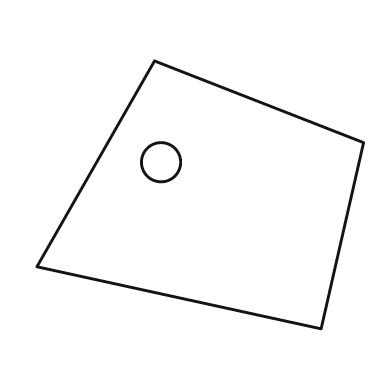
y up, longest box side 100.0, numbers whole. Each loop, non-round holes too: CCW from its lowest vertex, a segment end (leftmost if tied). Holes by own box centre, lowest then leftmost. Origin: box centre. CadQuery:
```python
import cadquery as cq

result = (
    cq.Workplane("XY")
    .moveTo(37.0, -41.0)
    .lineTo(50.0, 16.0)
    .lineTo(-14.0, 41.0)
    .lineTo(-50.0, -22.0)
    .close()
    .moveTo(-12.0, 10.0)
    .circle(6.0)
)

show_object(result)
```